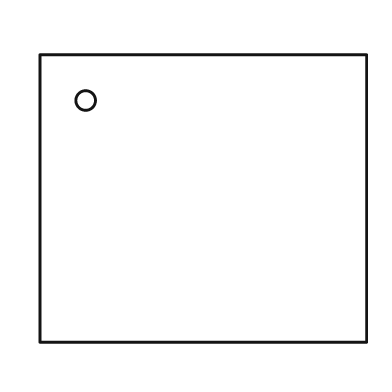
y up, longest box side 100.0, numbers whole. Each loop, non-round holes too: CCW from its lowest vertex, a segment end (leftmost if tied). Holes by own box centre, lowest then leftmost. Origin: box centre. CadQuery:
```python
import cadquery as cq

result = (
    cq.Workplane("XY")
    .moveTo(-50.0, -44.0)
    .lineTo(50.0, -44.0)
    .lineTo(50.0, 44.0)
    .lineTo(-50.0, 44.0)
    .close()
    .moveTo(-36.0, 30.0)
    .circle(3.0)
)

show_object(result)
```